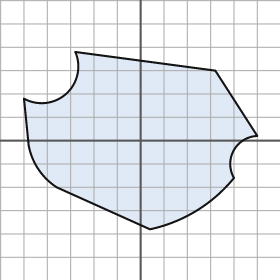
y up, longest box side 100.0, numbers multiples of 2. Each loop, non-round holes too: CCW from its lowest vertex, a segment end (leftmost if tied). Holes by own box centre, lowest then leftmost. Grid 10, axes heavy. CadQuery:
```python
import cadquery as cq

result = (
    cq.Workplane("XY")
    .moveTo(4.0, -38.0)
    .threePointArc((24.0, -30.0), (40.0, -16.0))
    .threePointArc((40.0, -4.0), (50.0, 2.0))
    .lineTo(32.0, 30.0)
    .lineTo(-28.0, 38.0)
    .threePointArc((-32.0, 20.0), (-50.0, 18.0))
    .lineTo(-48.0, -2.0)
    .threePointArc((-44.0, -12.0), (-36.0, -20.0))
    .close()
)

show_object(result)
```